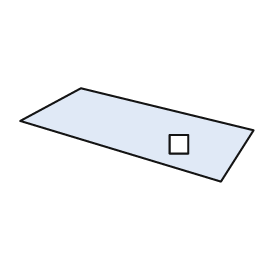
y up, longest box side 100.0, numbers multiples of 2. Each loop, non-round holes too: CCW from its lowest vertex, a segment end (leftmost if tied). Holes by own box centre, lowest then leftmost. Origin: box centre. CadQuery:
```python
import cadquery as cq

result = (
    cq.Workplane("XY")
    .moveTo(36.0, -20.0)
    .lineTo(50.0, 2.0)
    .lineTo(-24.0, 20.0)
    .lineTo(-50.0, 6.0)
    .close()
    .moveTo(14.0, -8.0)
    .lineTo(22.0, -8.0)
    .lineTo(22.0, 0.0)
    .lineTo(14.0, 0.0)
    .close()
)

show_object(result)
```